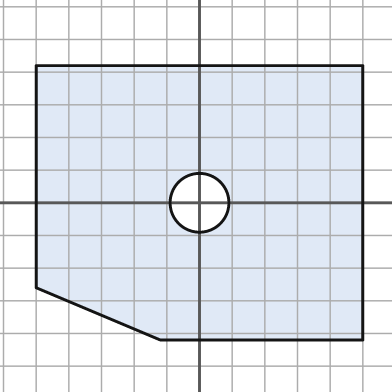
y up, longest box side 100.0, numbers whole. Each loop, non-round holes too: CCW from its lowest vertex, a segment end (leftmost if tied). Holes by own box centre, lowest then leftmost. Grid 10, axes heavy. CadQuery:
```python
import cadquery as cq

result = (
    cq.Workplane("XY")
    .moveTo(-12.0, -42.0)
    .lineTo(50.0, -42.0)
    .lineTo(50.0, 42.0)
    .lineTo(-50.0, 42.0)
    .lineTo(-50.0, -26.0)
    .close()
    .moveTo(0.0, 0.0)
    .circle(9.0)
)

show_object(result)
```